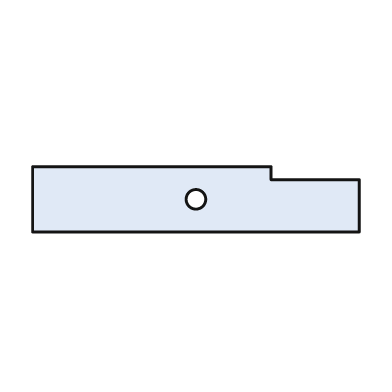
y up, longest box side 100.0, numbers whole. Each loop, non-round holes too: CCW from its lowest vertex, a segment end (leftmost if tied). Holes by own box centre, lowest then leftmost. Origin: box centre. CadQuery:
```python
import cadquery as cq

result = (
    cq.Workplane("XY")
    .moveTo(-50.0, -10.0)
    .lineTo(50.0, -10.0)
    .lineTo(50.0, 6.0)
    .lineTo(23.0, 6.0)
    .lineTo(23.0, 10.0)
    .lineTo(-50.0, 10.0)
    .close()
    .moveTo(0.0, 0.0)
    .circle(3.0)
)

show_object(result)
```